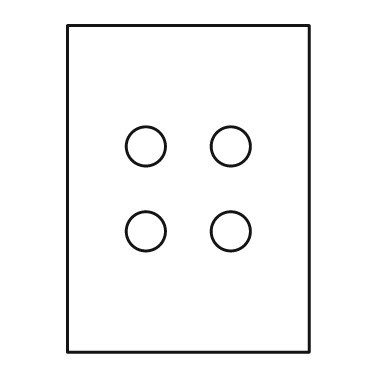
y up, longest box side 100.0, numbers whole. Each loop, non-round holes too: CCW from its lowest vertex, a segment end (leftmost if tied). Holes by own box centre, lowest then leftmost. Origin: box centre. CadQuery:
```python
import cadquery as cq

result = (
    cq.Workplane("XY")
    .moveTo(-37.0, -50.0)
    .lineTo(37.0, -50.0)
    .lineTo(37.0, 50.0)
    .lineTo(-37.0, 50.0)
    .close()
    .moveTo(-13.0, -13.0)
    .circle(6.0)
    .moveTo(13.0, -13.0)
    .circle(6.0)
    .moveTo(-13.0, 13.0)
    .circle(6.0)
    .moveTo(13.0, 13.0)
    .circle(6.0)
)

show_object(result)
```